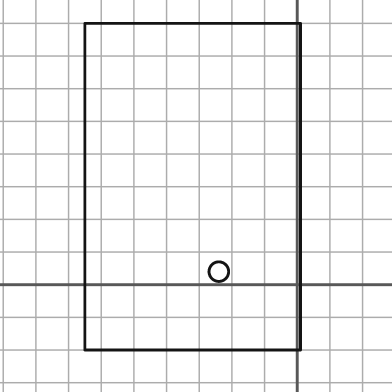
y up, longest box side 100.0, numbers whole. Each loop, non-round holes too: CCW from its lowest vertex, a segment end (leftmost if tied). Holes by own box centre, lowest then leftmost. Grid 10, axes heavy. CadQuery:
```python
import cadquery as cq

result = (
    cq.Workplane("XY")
    .moveTo(-65.0, -20.0)
    .lineTo(1.0, -20.0)
    .lineTo(1.0, 80.0)
    .lineTo(-65.0, 80.0)
    .close()
    .moveTo(-24.0, 4.0)
    .circle(3.0)
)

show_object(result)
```